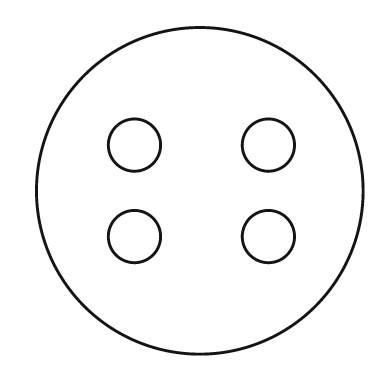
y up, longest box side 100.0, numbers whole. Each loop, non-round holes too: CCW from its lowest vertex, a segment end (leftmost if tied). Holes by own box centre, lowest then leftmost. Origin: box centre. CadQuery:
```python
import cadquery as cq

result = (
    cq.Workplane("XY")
    .moveTo(0.0, 0.0)
    .circle(50.0)
    .moveTo(-20.0, -14.0)
    .circle(8.0)
    .moveTo(21.0, -14.0)
    .circle(8.0)
    .moveTo(-20.0, 14.0)
    .circle(8.0)
    .moveTo(21.0, 14.0)
    .circle(8.0)
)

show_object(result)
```